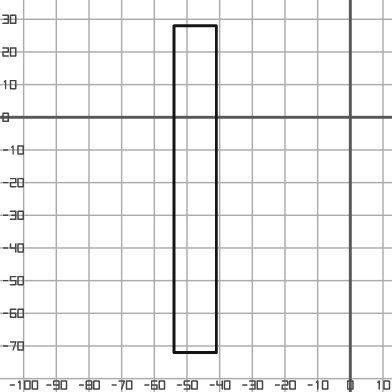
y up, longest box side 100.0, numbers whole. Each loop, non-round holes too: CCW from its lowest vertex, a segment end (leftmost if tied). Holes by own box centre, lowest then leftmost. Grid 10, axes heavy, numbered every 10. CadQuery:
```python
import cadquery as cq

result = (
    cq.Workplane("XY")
    .moveTo(-54.0, -72.0)
    .lineTo(-41.0, -72.0)
    .lineTo(-41.0, 28.0)
    .lineTo(-54.0, 28.0)
    .close()
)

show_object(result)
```